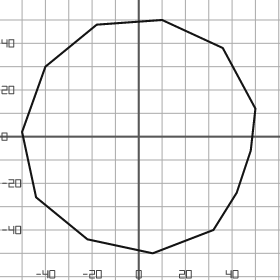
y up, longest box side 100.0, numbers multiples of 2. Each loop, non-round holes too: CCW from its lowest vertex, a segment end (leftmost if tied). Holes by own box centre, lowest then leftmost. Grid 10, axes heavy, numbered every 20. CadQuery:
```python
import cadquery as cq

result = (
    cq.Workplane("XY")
    .moveTo(6.0, -50.0)
    .lineTo(32.0, -40.0)
    .lineTo(42.0, -24.0)
    .lineTo(48.0, -6.0)
    .lineTo(50.0, 12.0)
    .lineTo(36.0, 38.0)
    .lineTo(10.0, 50.0)
    .lineTo(-18.0, 48.0)
    .lineTo(-40.0, 30.0)
    .lineTo(-50.0, 2.0)
    .lineTo(-44.0, -26.0)
    .lineTo(-22.0, -44.0)
    .close()
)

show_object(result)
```